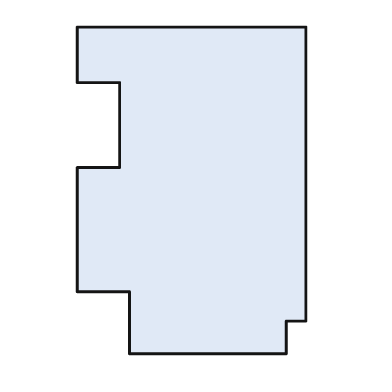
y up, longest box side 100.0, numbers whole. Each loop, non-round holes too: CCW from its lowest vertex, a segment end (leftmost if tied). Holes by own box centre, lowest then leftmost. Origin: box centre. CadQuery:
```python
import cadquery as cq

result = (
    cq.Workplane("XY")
    .moveTo(-19.0, -50.0)
    .lineTo(29.0, -50.0)
    .lineTo(29.0, -40.0)
    .lineTo(35.0, -40.0)
    .lineTo(35.0, 50.0)
    .lineTo(-35.0, 50.0)
    .lineTo(-35.0, 33.0)
    .lineTo(-22.0, 33.0)
    .lineTo(-22.0, 7.0)
    .lineTo(-35.0, 7.0)
    .lineTo(-35.0, -31.0)
    .lineTo(-19.0, -31.0)
    .close()
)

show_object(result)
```